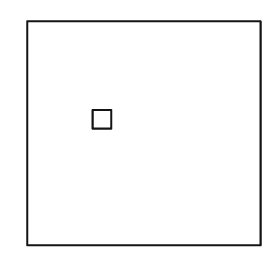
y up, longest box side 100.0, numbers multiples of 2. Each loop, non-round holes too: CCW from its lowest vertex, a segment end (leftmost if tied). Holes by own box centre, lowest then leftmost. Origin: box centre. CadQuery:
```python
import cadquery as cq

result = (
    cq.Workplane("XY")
    .moveTo(-50.0, -48.0)
    .lineTo(50.0, -48.0)
    .lineTo(50.0, 48.0)
    .lineTo(-50.0, 48.0)
    .close()
    .moveTo(-22.0, 2.0)
    .lineTo(-14.0, 2.0)
    .lineTo(-14.0, 10.0)
    .lineTo(-22.0, 10.0)
    .close()
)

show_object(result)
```